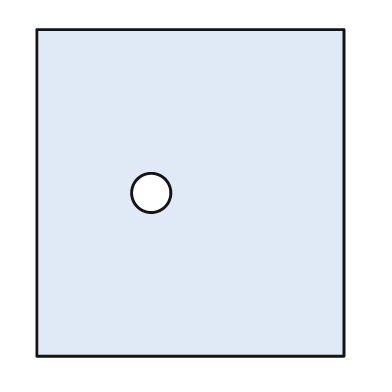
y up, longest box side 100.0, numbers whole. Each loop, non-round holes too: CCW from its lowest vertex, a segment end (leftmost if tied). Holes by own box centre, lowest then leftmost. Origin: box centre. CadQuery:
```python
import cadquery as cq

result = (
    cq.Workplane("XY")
    .moveTo(-47.0, -50.0)
    .lineTo(47.0, -50.0)
    .lineTo(47.0, 50.0)
    .lineTo(-47.0, 50.0)
    .close()
    .moveTo(-12.0, 0.0)
    .circle(6.0)
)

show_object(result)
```